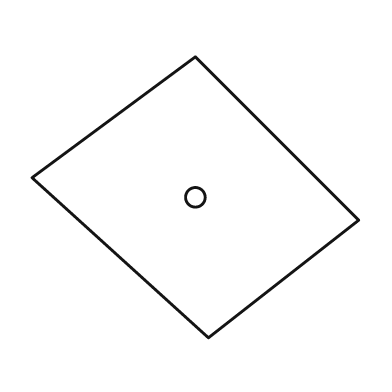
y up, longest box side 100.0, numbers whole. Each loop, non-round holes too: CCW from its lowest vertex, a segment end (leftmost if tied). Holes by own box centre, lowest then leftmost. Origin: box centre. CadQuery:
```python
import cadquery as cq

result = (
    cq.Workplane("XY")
    .moveTo(4.0, -43.0)
    .lineTo(50.0, -7.0)
    .lineTo(0.0, 43.0)
    .lineTo(-50.0, 6.0)
    .close()
    .moveTo(0.0, 0.0)
    .circle(3.0)
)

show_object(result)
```